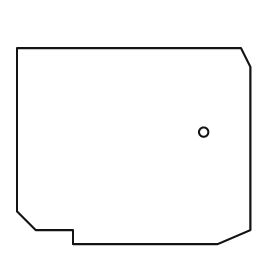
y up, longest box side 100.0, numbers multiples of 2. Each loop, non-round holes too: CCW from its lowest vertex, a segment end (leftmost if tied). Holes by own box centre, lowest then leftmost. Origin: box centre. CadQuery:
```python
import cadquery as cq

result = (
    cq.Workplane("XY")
    .moveTo(-26.0, -42.0)
    .lineTo(36.0, -42.0)
    .lineTo(50.0, -36.0)
    .lineTo(50.0, 34.0)
    .lineTo(46.0, 42.0)
    .lineTo(-50.0, 42.0)
    .lineTo(-50.0, -28.0)
    .lineTo(-42.0, -36.0)
    .lineTo(-26.0, -36.0)
    .close()
    .moveTo(30.0, 6.0)
    .circle(2.0)
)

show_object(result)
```